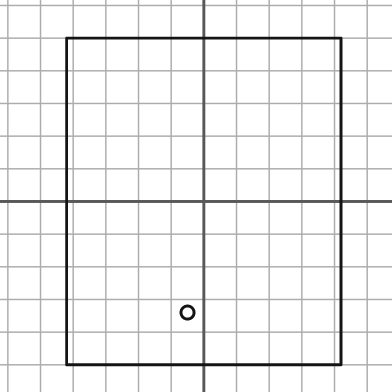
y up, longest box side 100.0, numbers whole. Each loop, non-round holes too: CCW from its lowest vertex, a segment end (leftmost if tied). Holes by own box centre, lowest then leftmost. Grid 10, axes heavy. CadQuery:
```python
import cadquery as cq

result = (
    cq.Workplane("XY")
    .moveTo(-42.0, -50.0)
    .lineTo(42.0, -50.0)
    .lineTo(42.0, 50.0)
    .lineTo(-42.0, 50.0)
    .close()
    .moveTo(-5.0, -34.0)
    .circle(2.0)
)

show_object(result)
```